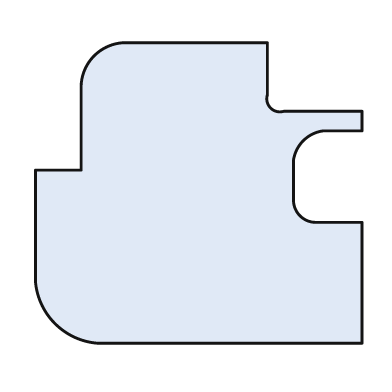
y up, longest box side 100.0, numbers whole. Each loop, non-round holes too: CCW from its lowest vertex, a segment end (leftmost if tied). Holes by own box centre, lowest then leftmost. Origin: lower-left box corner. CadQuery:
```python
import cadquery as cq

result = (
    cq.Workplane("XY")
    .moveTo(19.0, 0.0)
    .lineTo(100.0, 0.0)
    .lineTo(100.0, 37.0)
    .lineTo(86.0, 37.0)
    .threePointArc((81.0, 39.0), (79.0, 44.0))
    .lineTo(79.0, 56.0)
    .threePointArc((82.0, 62.0), (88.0, 65.0))
    .lineTo(100.0, 65.0)
    .lineTo(100.0, 71.0)
    .lineTo(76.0, 71.0)
    .threePointArc((72.0, 72.0), (71.0, 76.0))
    .lineTo(71.0, 92.0)
    .lineTo(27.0, 92.0)
    .threePointArc((18.0, 88.0), (14.0, 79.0))
    .lineTo(14.0, 53.0)
    .lineTo(0.0, 53.0)
    .lineTo(0.0, 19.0)
    .threePointArc((6.0, 6.0), (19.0, 0.0))
    .close()
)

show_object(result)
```